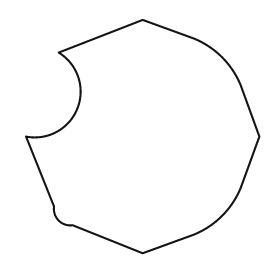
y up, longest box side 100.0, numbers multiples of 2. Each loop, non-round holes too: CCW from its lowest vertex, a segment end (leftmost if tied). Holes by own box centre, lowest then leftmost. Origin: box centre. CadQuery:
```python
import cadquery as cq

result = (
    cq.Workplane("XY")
    .moveTo(0.0, -50.0)
    .lineTo(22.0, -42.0)
    .threePointArc((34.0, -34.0), (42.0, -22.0))
    .lineTo(50.0, 0.0)
    .lineTo(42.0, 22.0)
    .threePointArc((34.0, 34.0), (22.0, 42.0))
    .lineTo(0.0, 50.0)
    .lineTo(-36.0, 36.0)
    .threePointArc((-28.0, 12.0), (-50.0, 0.0))
    .lineTo(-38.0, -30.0)
    .threePointArc((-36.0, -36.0), (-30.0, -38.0))
    .close()
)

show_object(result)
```